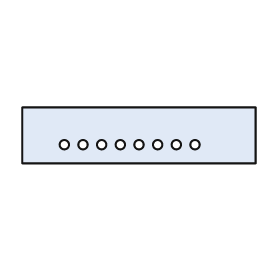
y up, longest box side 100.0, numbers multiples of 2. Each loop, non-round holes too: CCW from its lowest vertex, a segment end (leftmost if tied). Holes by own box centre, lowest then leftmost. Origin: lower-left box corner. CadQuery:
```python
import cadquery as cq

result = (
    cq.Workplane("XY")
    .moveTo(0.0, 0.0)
    .lineTo(100.0, 0.0)
    .lineTo(100.0, 24.0)
    .lineTo(0.0, 24.0)
    .close()
    .moveTo(18.0, 8.0)
    .circle(2.0)
    .moveTo(26.0, 8.0)
    .circle(2.0)
    .moveTo(34.0, 8.0)
    .circle(2.0)
    .moveTo(42.0, 8.0)
    .circle(2.0)
    .moveTo(50.0, 8.0)
    .circle(2.0)
    .moveTo(58.0, 8.0)
    .circle(2.0)
    .moveTo(66.0, 8.0)
    .circle(2.0)
    .moveTo(74.0, 8.0)
    .circle(2.0)
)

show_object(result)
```